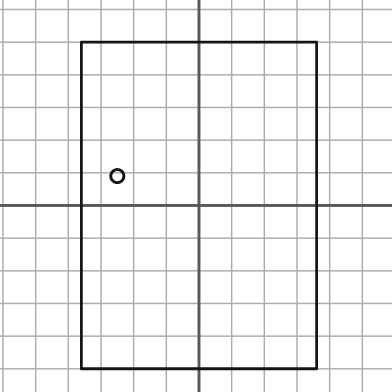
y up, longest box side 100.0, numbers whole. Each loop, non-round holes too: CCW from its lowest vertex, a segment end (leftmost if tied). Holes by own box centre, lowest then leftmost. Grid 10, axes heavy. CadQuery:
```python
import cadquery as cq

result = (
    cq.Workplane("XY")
    .moveTo(-36.0, -50.0)
    .lineTo(36.0, -50.0)
    .lineTo(36.0, 50.0)
    .lineTo(-36.0, 50.0)
    .close()
    .moveTo(-25.0, 9.0)
    .circle(2.0)
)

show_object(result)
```